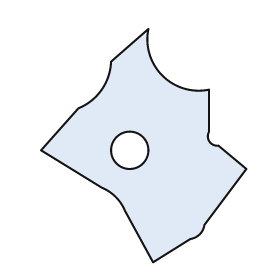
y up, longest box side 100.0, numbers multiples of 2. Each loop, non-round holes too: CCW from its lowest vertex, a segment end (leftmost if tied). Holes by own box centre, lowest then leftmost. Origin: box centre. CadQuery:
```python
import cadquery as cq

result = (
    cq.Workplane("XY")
    .moveTo(4.0, -50.0)
    .lineTo(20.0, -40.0)
    .threePointArc((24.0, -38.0), (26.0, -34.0))
    .lineTo(44.0, -10.0)
    .lineTo(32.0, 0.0)
    .threePointArc((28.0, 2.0), (28.0, 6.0))
    .lineTo(28.0, 24.0)
    .threePointArc((8.0, 30.0), (2.0, 50.0))
    .lineTo(-14.0, 36.0)
    .threePointArc((-18.0, 24.0), (-28.0, 16.0))
    .lineTo(-44.0, -2.0)
    .lineTo(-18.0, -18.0)
    .threePointArc((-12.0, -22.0), (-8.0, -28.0))
    .close()
    .moveTo(-6.0, -2.0)
    .circle(8.0)
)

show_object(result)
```